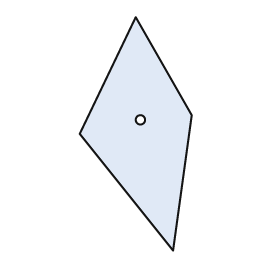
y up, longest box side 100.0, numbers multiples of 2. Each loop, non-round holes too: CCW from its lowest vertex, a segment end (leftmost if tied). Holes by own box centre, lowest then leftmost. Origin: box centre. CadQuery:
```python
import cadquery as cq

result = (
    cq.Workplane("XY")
    .moveTo(16.0, -50.0)
    .lineTo(24.0, 8.0)
    .lineTo(0.0, 50.0)
    .lineTo(-24.0, 0.0)
    .close()
    .moveTo(2.0, 6.0)
    .circle(2.0)
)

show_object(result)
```